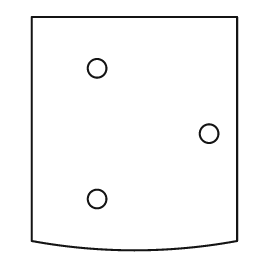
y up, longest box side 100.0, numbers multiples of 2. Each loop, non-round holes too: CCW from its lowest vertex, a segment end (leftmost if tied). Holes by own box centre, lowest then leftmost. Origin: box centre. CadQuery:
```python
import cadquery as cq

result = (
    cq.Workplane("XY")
    .moveTo(-44.0, -46.0)
    .threePointArc((0.0, -50.0), (44.0, -46.0))
    .lineTo(44.0, 50.0)
    .lineTo(-44.0, 50.0)
    .close()
    .moveTo(-16.0, -28.0)
    .circle(4.0)
    .moveTo(32.0, 0.0)
    .circle(4.0)
    .moveTo(-16.0, 28.0)
    .circle(4.0)
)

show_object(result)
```